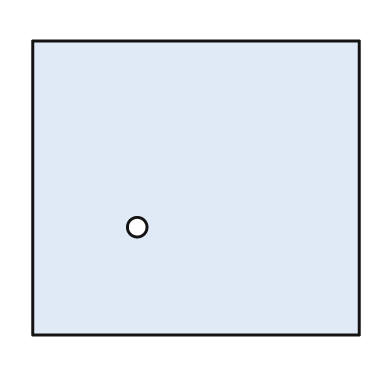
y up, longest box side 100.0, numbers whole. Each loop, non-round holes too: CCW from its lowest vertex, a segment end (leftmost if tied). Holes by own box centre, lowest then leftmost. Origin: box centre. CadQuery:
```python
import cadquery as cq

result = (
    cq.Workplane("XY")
    .moveTo(-50.0, -45.0)
    .lineTo(50.0, -45.0)
    .lineTo(50.0, 45.0)
    .lineTo(-50.0, 45.0)
    .close()
    .moveTo(-18.0, -12.0)
    .circle(3.0)
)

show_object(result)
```